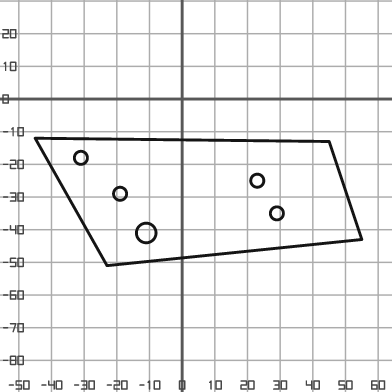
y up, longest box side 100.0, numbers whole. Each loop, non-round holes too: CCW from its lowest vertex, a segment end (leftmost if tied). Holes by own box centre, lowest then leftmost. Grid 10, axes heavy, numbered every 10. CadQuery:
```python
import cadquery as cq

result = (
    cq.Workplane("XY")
    .moveTo(-23.0, -51.0)
    .lineTo(55.0, -43.0)
    .lineTo(45.0, -13.0)
    .lineTo(-45.0, -12.0)
    .close()
    .moveTo(-11.0, -41.0)
    .circle(3.0)
    .moveTo(29.0, -35.0)
    .circle(2.0)
    .moveTo(-19.0, -29.0)
    .circle(2.0)
    .moveTo(23.0, -25.0)
    .circle(2.0)
    .moveTo(-31.0, -18.0)
    .circle(2.0)
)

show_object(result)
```